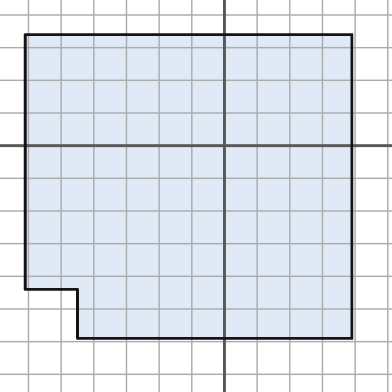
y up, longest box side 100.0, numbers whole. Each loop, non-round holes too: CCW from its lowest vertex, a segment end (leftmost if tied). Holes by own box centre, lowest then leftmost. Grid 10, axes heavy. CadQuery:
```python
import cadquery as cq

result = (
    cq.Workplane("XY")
    .moveTo(-45.0, -59.0)
    .lineTo(39.0, -59.0)
    .lineTo(39.0, 34.0)
    .lineTo(-61.0, 34.0)
    .lineTo(-61.0, -44.0)
    .lineTo(-45.0, -44.0)
    .close()
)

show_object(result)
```